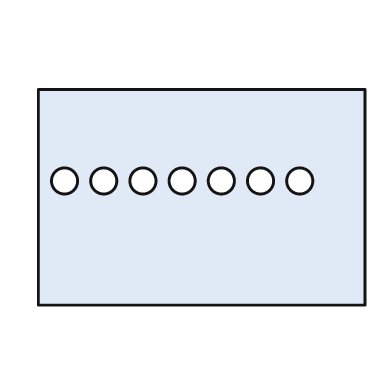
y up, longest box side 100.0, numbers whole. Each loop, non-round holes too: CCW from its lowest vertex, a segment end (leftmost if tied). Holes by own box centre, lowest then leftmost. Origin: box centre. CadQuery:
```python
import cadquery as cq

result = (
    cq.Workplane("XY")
    .moveTo(-50.0, -33.0)
    .lineTo(50.0, -33.0)
    .lineTo(50.0, 33.0)
    .lineTo(-50.0, 33.0)
    .close()
    .moveTo(-42.0, 5.0)
    .circle(4.0)
    .moveTo(-30.0, 5.0)
    .circle(4.0)
    .moveTo(-18.0, 5.0)
    .circle(4.0)
    .moveTo(-6.0, 5.0)
    .circle(4.0)
    .moveTo(6.0, 5.0)
    .circle(4.0)
    .moveTo(18.0, 5.0)
    .circle(4.0)
    .moveTo(30.0, 5.0)
    .circle(4.0)
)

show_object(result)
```